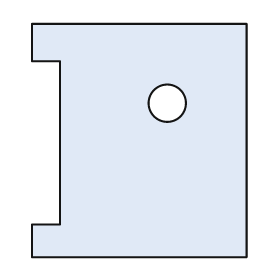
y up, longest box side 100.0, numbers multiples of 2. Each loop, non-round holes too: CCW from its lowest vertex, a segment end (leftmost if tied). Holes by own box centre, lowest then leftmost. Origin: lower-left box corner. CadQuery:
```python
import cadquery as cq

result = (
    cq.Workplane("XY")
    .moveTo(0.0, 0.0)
    .lineTo(92.0, 0.0)
    .lineTo(92.0, 100.0)
    .lineTo(0.0, 100.0)
    .lineTo(0.0, 84.0)
    .lineTo(12.0, 84.0)
    .lineTo(12.0, 14.0)
    .lineTo(0.0, 14.0)
    .close()
    .moveTo(58.0, 66.0)
    .circle(8.0)
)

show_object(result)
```